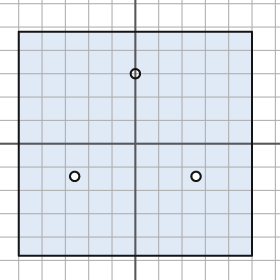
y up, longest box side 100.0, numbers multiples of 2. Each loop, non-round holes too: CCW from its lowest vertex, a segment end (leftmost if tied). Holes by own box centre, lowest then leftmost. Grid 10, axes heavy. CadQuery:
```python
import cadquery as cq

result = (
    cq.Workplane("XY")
    .moveTo(-50.0, -48.0)
    .lineTo(50.0, -48.0)
    .lineTo(50.0, 48.0)
    .lineTo(-50.0, 48.0)
    .close()
    .moveTo(-26.0, -14.0)
    .circle(2.0)
    .moveTo(26.0, -14.0)
    .circle(2.0)
    .moveTo(0.0, 30.0)
    .circle(2.0)
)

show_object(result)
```